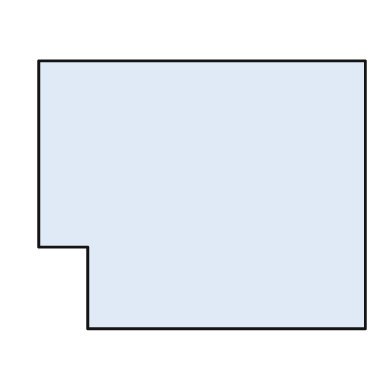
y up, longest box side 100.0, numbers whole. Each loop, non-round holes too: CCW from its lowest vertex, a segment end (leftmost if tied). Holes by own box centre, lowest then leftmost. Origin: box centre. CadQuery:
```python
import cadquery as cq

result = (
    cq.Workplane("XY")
    .moveTo(-35.0, -41.0)
    .lineTo(50.0, -41.0)
    .lineTo(50.0, 41.0)
    .lineTo(-50.0, 41.0)
    .lineTo(-50.0, -16.0)
    .lineTo(-35.0, -16.0)
    .close()
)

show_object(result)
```